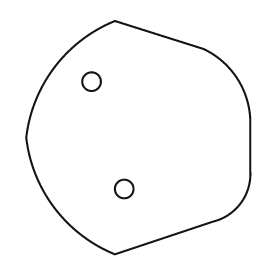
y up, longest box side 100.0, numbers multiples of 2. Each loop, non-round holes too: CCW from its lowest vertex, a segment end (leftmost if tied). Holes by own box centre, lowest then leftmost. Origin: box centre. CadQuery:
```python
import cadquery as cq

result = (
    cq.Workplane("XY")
    .moveTo(-10.0, -50.0)
    .lineTo(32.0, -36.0)
    .threePointArc((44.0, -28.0), (48.0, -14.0))
    .lineTo(48.0, 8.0)
    .threePointArc((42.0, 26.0), (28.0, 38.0))
    .lineTo(-10.0, 50.0)
    .threePointArc((-36.0, 30.0), (-48.0, 0.0))
    .threePointArc((-36.0, -30.0), (-10.0, -50.0))
    .close()
    .moveTo(-6.0, -22.0)
    .circle(4.0)
    .moveTo(-20.0, 24.0)
    .circle(4.0)
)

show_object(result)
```